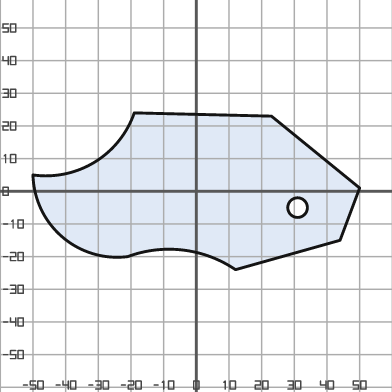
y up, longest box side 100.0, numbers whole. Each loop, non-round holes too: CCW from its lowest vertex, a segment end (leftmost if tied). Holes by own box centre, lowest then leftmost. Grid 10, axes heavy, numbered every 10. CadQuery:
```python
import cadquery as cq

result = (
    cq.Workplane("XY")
    .moveTo(12.0, -24.0)
    .lineTo(44.0, -15.0)
    .lineTo(50.0, 1.0)
    .lineTo(23.0, 23.0)
    .lineTo(-19.0, 24.0)
    .threePointArc((-31.0, 9.0), (-50.0, 5.0))
    .threePointArc((-41.0, -14.0), (-21.0, -20.0))
    .threePointArc((-4.0, -18.0), (12.0, -24.0))
    .close()
    .moveTo(31.0, -5.0)
    .circle(3.0)
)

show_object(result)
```